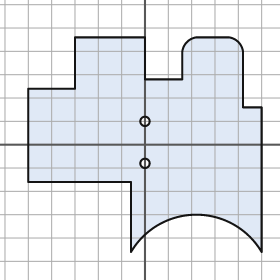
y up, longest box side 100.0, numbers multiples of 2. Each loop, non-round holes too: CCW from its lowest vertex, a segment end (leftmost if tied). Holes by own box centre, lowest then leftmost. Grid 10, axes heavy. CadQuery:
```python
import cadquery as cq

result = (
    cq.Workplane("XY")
    .moveTo(-6.0, -46.0)
    .threePointArc((22.0, -30.0), (50.0, -46.0))
    .lineTo(50.0, 16.0)
    .lineTo(42.0, 16.0)
    .lineTo(42.0, 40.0)
    .threePointArc((40.0, 44.0), (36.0, 46.0))
    .lineTo(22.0, 46.0)
    .threePointArc((18.0, 44.0), (16.0, 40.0))
    .lineTo(16.0, 28.0)
    .lineTo(0.0, 28.0)
    .lineTo(0.0, 46.0)
    .lineTo(-30.0, 46.0)
    .lineTo(-30.0, 24.0)
    .lineTo(-50.0, 24.0)
    .lineTo(-50.0, -16.0)
    .lineTo(-6.0, -16.0)
    .close()
    .moveTo(0.0, -8.0)
    .circle(2.0)
    .moveTo(0.0, 10.0)
    .circle(2.0)
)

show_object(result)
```